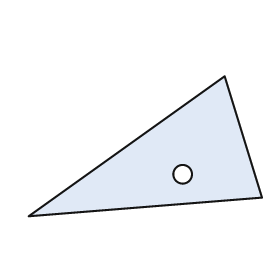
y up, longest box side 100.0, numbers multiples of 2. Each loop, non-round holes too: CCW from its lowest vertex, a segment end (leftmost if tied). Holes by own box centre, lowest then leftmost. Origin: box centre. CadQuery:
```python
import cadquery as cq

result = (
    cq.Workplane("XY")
    .moveTo(-50.0, -30.0)
    .lineTo(50.0, -22.0)
    .lineTo(34.0, 30.0)
    .close()
    .moveTo(16.0, -12.0)
    .circle(4.0)
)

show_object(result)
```